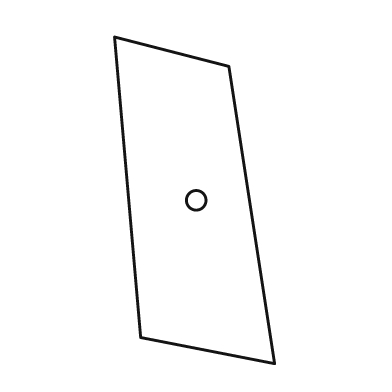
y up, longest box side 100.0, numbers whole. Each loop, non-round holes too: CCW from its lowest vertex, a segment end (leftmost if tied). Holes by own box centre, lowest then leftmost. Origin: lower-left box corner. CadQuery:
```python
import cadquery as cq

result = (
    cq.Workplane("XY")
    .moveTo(49.0, 0.0)
    .lineTo(35.0, 91.0)
    .lineTo(0.0, 100.0)
    .lineTo(8.0, 8.0)
    .close()
    .moveTo(25.0, 50.0)
    .circle(3.0)
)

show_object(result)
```